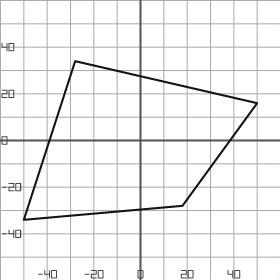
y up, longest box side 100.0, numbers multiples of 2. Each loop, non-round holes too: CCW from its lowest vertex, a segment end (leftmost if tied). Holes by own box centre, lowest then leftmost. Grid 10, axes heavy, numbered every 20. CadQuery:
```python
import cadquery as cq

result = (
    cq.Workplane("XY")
    .moveTo(-50.0, -34.0)
    .lineTo(18.0, -28.0)
    .lineTo(50.0, 16.0)
    .lineTo(-28.0, 34.0)
    .close()
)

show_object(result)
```